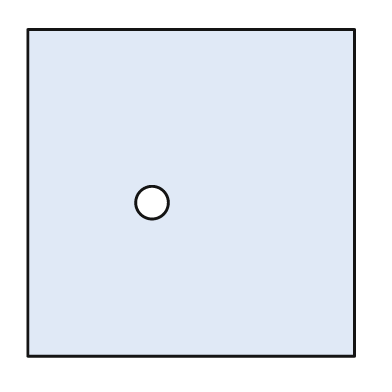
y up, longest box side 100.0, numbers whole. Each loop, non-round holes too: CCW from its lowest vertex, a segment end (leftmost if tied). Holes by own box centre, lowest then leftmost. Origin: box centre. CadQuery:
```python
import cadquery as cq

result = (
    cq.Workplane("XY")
    .moveTo(-50.0, -50.0)
    .lineTo(50.0, -50.0)
    .lineTo(50.0, 50.0)
    .lineTo(-50.0, 50.0)
    .close()
    .moveTo(-12.0, -3.0)
    .circle(5.0)
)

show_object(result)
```